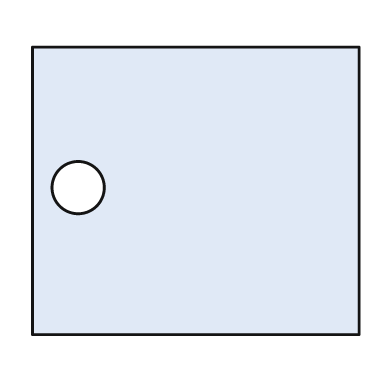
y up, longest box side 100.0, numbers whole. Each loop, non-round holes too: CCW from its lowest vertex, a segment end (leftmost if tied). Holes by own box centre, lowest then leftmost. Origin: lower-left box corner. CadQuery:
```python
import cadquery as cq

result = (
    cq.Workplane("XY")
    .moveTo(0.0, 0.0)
    .lineTo(100.0, 0.0)
    .lineTo(100.0, 88.0)
    .lineTo(0.0, 88.0)
    .close()
    .moveTo(14.0, 45.0)
    .circle(8.0)
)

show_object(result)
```